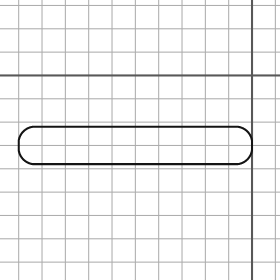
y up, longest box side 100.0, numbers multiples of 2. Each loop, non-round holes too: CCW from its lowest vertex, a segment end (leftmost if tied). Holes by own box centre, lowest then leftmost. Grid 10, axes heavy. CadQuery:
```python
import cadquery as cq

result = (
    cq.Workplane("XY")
    .moveTo(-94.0, -38.0)
    .lineTo(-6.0, -38.0)
    .threePointArc((-2.0, -36.0), (0.0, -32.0))
    .lineTo(0.0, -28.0)
    .threePointArc((-2.0, -24.0), (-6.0, -22.0))
    .lineTo(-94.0, -22.0)
    .threePointArc((-98.0, -24.0), (-100.0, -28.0))
    .lineTo(-100.0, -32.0)
    .threePointArc((-98.0, -36.0), (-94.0, -38.0))
    .close()
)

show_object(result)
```